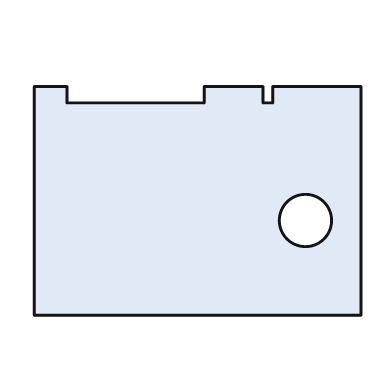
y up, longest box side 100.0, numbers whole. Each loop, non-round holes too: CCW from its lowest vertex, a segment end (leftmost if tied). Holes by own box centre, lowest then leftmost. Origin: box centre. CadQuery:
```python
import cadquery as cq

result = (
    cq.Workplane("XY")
    .moveTo(-50.0, -35.0)
    .lineTo(50.0, -35.0)
    .lineTo(50.0, 35.0)
    .lineTo(23.0, 35.0)
    .lineTo(23.0, 30.0)
    .lineTo(20.0, 30.0)
    .lineTo(20.0, 35.0)
    .lineTo(2.0, 35.0)
    .lineTo(2.0, 30.0)
    .lineTo(-40.0, 30.0)
    .lineTo(-40.0, 35.0)
    .lineTo(-50.0, 35.0)
    .close()
    .moveTo(33.0, -6.0)
    .circle(8.0)
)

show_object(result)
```